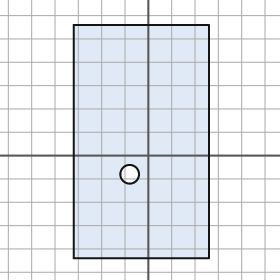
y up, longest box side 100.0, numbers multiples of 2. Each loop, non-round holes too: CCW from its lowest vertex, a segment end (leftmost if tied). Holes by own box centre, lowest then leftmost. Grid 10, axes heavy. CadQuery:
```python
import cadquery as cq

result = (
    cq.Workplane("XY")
    .moveTo(-32.0, -44.0)
    .lineTo(26.0, -44.0)
    .lineTo(26.0, 56.0)
    .lineTo(-32.0, 56.0)
    .close()
    .moveTo(-8.0, -8.0)
    .circle(4.0)
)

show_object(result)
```